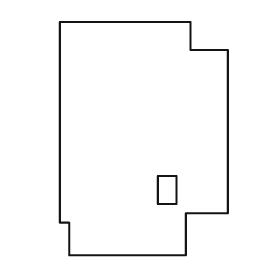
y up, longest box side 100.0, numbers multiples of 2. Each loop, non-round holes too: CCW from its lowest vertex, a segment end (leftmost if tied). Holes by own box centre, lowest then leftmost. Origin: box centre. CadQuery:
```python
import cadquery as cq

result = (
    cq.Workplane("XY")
    .moveTo(-32.0, -50.0)
    .lineTo(18.0, -50.0)
    .lineTo(18.0, -32.0)
    .lineTo(36.0, -32.0)
    .lineTo(36.0, 38.0)
    .lineTo(20.0, 38.0)
    .lineTo(20.0, 50.0)
    .lineTo(-36.0, 50.0)
    .lineTo(-36.0, -36.0)
    .lineTo(-32.0, -36.0)
    .close()
    .moveTo(6.0, -28.0)
    .lineTo(14.0, -28.0)
    .lineTo(14.0, -16.0)
    .lineTo(6.0, -16.0)
    .close()
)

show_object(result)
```